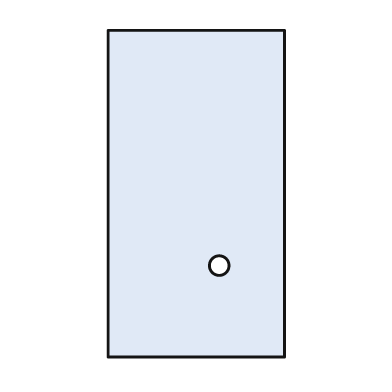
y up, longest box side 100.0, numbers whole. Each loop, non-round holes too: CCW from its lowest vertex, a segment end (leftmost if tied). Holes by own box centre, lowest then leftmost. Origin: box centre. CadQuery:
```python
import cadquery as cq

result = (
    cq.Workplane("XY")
    .moveTo(-27.0, -50.0)
    .lineTo(27.0, -50.0)
    .lineTo(27.0, 50.0)
    .lineTo(-27.0, 50.0)
    .close()
    .moveTo(7.0, -22.0)
    .circle(3.0)
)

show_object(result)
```